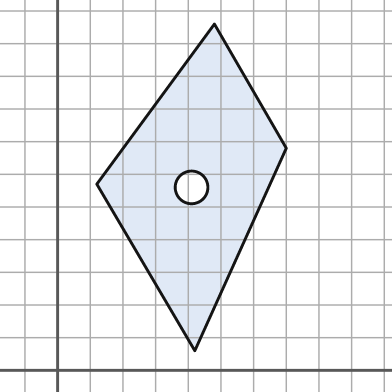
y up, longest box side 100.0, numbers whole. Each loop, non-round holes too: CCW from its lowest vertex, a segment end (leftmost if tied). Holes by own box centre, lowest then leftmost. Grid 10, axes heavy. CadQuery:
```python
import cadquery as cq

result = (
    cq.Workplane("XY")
    .moveTo(42.0, 6.0)
    .lineTo(70.0, 68.0)
    .lineTo(48.0, 106.0)
    .lineTo(12.0, 57.0)
    .close()
    .moveTo(41.0, 56.0)
    .circle(5.0)
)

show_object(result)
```